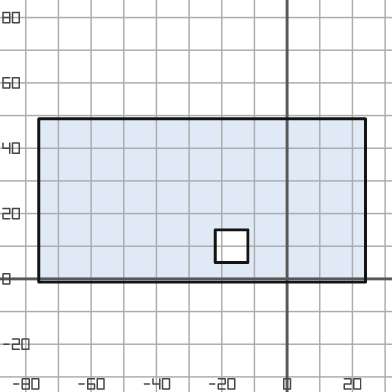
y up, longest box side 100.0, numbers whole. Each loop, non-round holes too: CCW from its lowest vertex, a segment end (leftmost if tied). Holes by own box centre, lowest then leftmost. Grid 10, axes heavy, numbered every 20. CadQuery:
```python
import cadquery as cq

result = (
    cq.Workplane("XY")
    .moveTo(-76.0, -1.0)
    .lineTo(24.0, -1.0)
    .lineTo(24.0, 49.0)
    .lineTo(-76.0, 49.0)
    .close()
    .moveTo(-22.0, 5.0)
    .lineTo(-12.0, 5.0)
    .lineTo(-12.0, 15.0)
    .lineTo(-22.0, 15.0)
    .close()
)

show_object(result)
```